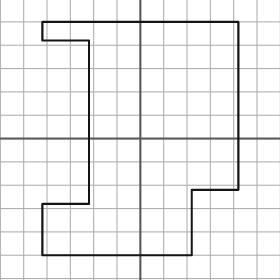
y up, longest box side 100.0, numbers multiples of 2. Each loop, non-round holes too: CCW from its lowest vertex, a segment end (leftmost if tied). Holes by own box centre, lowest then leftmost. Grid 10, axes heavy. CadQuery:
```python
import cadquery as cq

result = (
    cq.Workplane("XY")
    .moveTo(-42.0, -50.0)
    .lineTo(22.0, -50.0)
    .lineTo(22.0, -22.0)
    .lineTo(42.0, -22.0)
    .lineTo(42.0, 50.0)
    .lineTo(-42.0, 50.0)
    .lineTo(-42.0, 42.0)
    .lineTo(-22.0, 42.0)
    .lineTo(-22.0, -28.0)
    .lineTo(-42.0, -28.0)
    .close()
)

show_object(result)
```